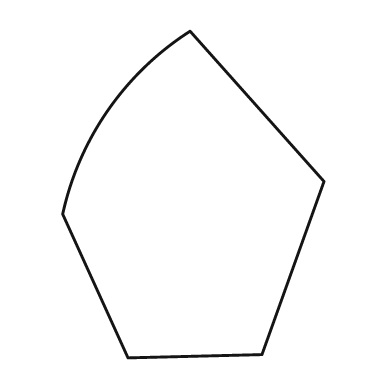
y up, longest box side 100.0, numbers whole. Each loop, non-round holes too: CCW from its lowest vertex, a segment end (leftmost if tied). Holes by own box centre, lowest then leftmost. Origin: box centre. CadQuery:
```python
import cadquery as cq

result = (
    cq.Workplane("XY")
    .moveTo(-20.0, -50.0)
    .lineTo(21.0, -49.0)
    .lineTo(40.0, 4.0)
    .lineTo(-1.0, 50.0)
    .threePointArc((-26.0, 26.0), (-40.0, -6.0))
    .close()
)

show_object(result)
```